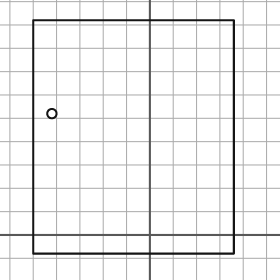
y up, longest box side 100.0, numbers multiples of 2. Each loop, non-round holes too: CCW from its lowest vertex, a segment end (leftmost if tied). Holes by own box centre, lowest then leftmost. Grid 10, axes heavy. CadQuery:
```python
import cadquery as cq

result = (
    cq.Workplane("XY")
    .moveTo(-50.0, -8.0)
    .lineTo(36.0, -8.0)
    .lineTo(36.0, 92.0)
    .lineTo(-50.0, 92.0)
    .close()
    .moveTo(-42.0, 52.0)
    .circle(2.0)
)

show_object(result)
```